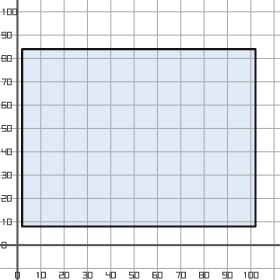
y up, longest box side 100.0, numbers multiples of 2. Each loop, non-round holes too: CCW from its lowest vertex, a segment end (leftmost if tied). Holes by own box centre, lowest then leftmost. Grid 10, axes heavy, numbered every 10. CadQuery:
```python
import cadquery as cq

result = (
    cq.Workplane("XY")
    .moveTo(2.0, 8.0)
    .lineTo(102.0, 8.0)
    .lineTo(102.0, 84.0)
    .lineTo(2.0, 84.0)
    .close()
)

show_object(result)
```